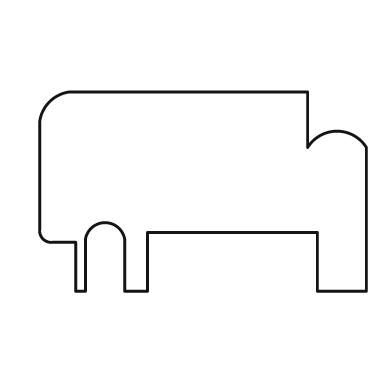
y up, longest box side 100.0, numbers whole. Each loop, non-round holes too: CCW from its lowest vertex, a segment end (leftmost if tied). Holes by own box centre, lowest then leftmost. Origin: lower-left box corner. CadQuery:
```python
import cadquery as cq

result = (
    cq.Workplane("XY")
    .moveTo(11.0, 0.0)
    .lineTo(14.0, 0.0)
    .lineTo(14.0, 16.0)
    .threePointArc((20.0, 21.0), (26.0, 16.0))
    .lineTo(26.0, 0.0)
    .lineTo(33.0, 0.0)
    .lineTo(33.0, 18.0)
    .lineTo(85.0, 18.0)
    .lineTo(85.0, 0.0)
    .lineTo(100.0, 0.0)
    .lineTo(100.0, 44.0)
    .threePointArc((91.0, 49.0), (82.0, 44.0))
    .lineTo(82.0, 61.0)
    .lineTo(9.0, 61.0)
    .threePointArc((3.0, 58.0), (0.0, 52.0))
    .lineTo(0.0, 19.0)
    .threePointArc((1.0, 16.0), (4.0, 15.0))
    .lineTo(11.0, 15.0)
    .close()
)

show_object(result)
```